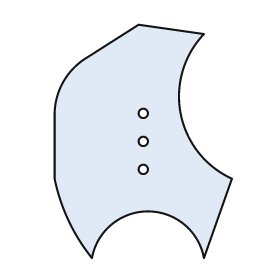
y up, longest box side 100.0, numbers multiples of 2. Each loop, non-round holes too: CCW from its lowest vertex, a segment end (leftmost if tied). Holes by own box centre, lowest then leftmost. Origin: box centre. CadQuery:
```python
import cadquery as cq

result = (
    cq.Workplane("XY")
    .moveTo(-22.0, -50.0)
    .threePointArc((2.0, -30.0), (26.0, -50.0))
    .lineTo(38.0, -16.0)
    .threePointArc((16.0, 12.0), (26.0, 46.0))
    .lineTo(-2.0, 50.0)
    .lineTo(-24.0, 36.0)
    .threePointArc((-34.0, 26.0), (-38.0, 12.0))
    .lineTo(-38.0, -16.0)
    .threePointArc((-32.0, -34.0), (-22.0, -50.0))
    .close()
    .moveTo(0.0, -12.0)
    .circle(2.0)
    .moveTo(0.0, 0.0)
    .circle(2.0)
    .moveTo(0.0, 12.0)
    .circle(2.0)
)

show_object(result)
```